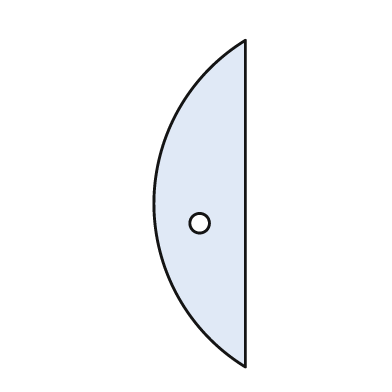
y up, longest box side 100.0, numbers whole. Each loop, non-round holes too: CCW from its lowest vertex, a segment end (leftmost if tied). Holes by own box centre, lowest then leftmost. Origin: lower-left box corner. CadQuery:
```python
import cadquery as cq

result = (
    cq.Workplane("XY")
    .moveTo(28.0, 0.0)
    .lineTo(28.0, 100.0)
    .threePointArc((0.0, 50.0), (28.0, 0.0))
    .close()
    .moveTo(14.0, 44.0)
    .circle(3.0)
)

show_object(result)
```